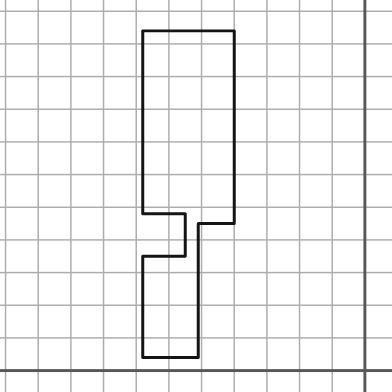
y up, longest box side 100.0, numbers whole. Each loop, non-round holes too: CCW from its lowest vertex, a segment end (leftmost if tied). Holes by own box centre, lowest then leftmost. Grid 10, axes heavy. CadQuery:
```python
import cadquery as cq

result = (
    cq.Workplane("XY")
    .moveTo(-68.0, 4.0)
    .lineTo(-51.0, 4.0)
    .lineTo(-51.0, 45.0)
    .lineTo(-40.0, 45.0)
    .lineTo(-40.0, 104.0)
    .lineTo(-68.0, 104.0)
    .lineTo(-68.0, 48.0)
    .lineTo(-55.0, 48.0)
    .lineTo(-55.0, 35.0)
    .lineTo(-68.0, 35.0)
    .close()
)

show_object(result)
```